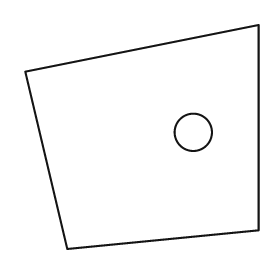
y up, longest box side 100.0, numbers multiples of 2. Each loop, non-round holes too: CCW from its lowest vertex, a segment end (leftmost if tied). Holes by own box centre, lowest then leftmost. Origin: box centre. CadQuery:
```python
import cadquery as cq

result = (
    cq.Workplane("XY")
    .moveTo(-32.0, -48.0)
    .lineTo(50.0, -40.0)
    .lineTo(50.0, 48.0)
    .lineTo(-50.0, 28.0)
    .close()
    .moveTo(22.0, 2.0)
    .circle(8.0)
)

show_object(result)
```